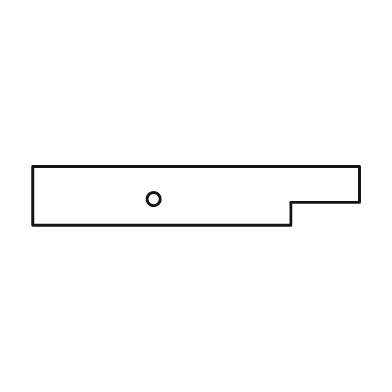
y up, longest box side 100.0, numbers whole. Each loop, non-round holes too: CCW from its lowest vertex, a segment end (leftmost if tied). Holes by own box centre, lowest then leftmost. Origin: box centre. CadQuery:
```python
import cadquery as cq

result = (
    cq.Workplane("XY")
    .moveTo(-50.0, -9.0)
    .lineTo(29.0, -9.0)
    .lineTo(29.0, -2.0)
    .lineTo(50.0, -2.0)
    .lineTo(50.0, 9.0)
    .lineTo(-50.0, 9.0)
    .close()
    .moveTo(-13.0, -1.0)
    .circle(2.0)
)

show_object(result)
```